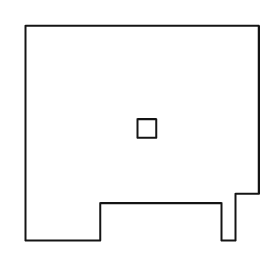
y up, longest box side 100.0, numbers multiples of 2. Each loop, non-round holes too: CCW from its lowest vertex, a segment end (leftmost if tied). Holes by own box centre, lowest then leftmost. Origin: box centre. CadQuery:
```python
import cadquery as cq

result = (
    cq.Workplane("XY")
    .moveTo(-50.0, -46.0)
    .lineTo(-18.0, -46.0)
    .lineTo(-18.0, -30.0)
    .lineTo(34.0, -30.0)
    .lineTo(34.0, -46.0)
    .lineTo(40.0, -46.0)
    .lineTo(40.0, -26.0)
    .lineTo(50.0, -26.0)
    .lineTo(50.0, 46.0)
    .lineTo(-50.0, 46.0)
    .close()
    .moveTo(-2.0, -2.0)
    .lineTo(6.0, -2.0)
    .lineTo(6.0, 6.0)
    .lineTo(-2.0, 6.0)
    .close()
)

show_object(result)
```